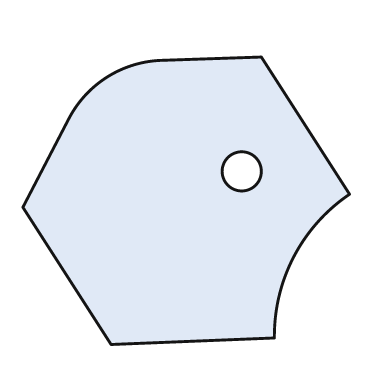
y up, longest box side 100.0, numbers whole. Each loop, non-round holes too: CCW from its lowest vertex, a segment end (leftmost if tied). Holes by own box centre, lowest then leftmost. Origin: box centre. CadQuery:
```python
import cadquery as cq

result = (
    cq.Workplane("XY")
    .moveTo(-23.0, -44.0)
    .lineTo(27.0, -42.0)
    .threePointArc((33.0, -17.0), (50.0, 2.0))
    .lineTo(23.0, 44.0)
    .lineTo(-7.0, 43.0)
    .threePointArc((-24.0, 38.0), (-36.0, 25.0))
    .lineTo(-50.0, -2.0)
    .close()
    .moveTo(17.0, 9.0)
    .circle(6.0)
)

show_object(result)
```